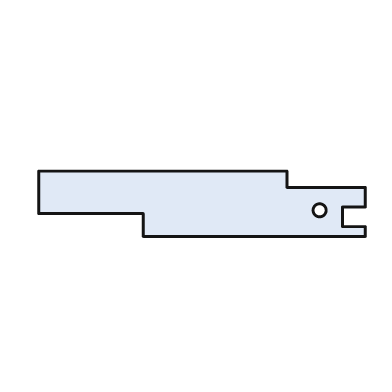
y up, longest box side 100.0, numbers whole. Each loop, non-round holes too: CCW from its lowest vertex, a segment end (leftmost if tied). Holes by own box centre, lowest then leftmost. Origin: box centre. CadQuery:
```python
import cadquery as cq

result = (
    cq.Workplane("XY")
    .moveTo(-18.0, -10.0)
    .lineTo(50.0, -10.0)
    .lineTo(50.0, -7.0)
    .lineTo(43.0, -7.0)
    .lineTo(43.0, -1.0)
    .lineTo(50.0, -1.0)
    .lineTo(50.0, 5.0)
    .lineTo(26.0, 5.0)
    .lineTo(26.0, 10.0)
    .lineTo(-50.0, 10.0)
    .lineTo(-50.0, -3.0)
    .lineTo(-18.0, -3.0)
    .close()
    .moveTo(36.0, -2.0)
    .circle(2.0)
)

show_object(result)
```